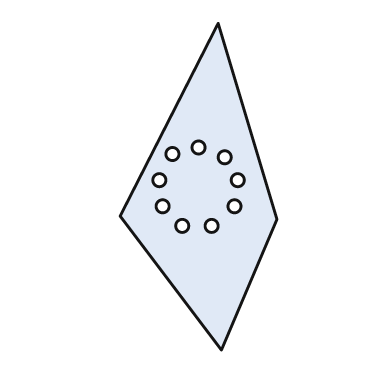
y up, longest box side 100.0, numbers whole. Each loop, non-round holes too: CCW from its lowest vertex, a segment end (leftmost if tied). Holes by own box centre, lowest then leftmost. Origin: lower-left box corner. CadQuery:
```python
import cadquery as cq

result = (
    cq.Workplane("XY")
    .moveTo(31.0, 0.0)
    .lineTo(48.0, 40.0)
    .lineTo(30.0, 100.0)
    .lineTo(0.0, 41.0)
    .close()
    .moveTo(19.0, 38.0)
    .circle(2.0)
    .moveTo(28.0, 38.0)
    .circle(2.0)
    .moveTo(13.0, 44.0)
    .circle(2.0)
    .moveTo(35.0, 44.0)
    .circle(2.0)
    .moveTo(12.0, 52.0)
    .circle(2.0)
    .moveTo(36.0, 52.0)
    .circle(2.0)
    .moveTo(32.0, 59.0)
    .circle(2.0)
    .moveTo(16.0, 60.0)
    .circle(2.0)
    .moveTo(24.0, 62.0)
    .circle(2.0)
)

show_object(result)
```